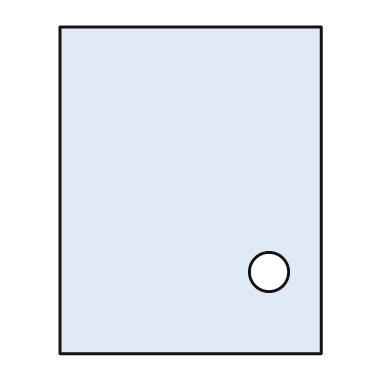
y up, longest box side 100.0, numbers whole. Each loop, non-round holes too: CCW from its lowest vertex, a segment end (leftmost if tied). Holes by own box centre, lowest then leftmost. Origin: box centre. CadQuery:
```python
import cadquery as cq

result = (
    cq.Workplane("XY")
    .moveTo(-40.0, -50.0)
    .lineTo(40.0, -50.0)
    .lineTo(40.0, 50.0)
    .lineTo(-40.0, 50.0)
    .close()
    .moveTo(24.0, -25.0)
    .circle(6.0)
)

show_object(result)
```